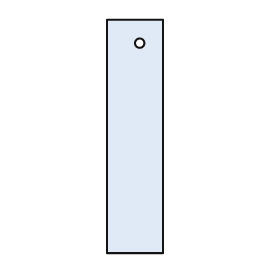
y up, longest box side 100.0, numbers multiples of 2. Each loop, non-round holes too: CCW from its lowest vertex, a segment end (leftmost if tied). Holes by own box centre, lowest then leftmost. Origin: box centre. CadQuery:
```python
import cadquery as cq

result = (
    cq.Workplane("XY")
    .moveTo(-12.0, -50.0)
    .lineTo(12.0, -50.0)
    .lineTo(12.0, 50.0)
    .lineTo(-12.0, 50.0)
    .close()
    .moveTo(2.0, 40.0)
    .circle(2.0)
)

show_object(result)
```